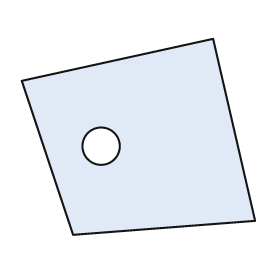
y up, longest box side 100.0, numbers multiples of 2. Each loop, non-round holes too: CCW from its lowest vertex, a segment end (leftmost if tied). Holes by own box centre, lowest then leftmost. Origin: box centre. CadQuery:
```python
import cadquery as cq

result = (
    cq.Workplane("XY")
    .moveTo(-28.0, -42.0)
    .lineTo(50.0, -36.0)
    .lineTo(32.0, 42.0)
    .lineTo(-50.0, 24.0)
    .close()
    .moveTo(-16.0, -4.0)
    .circle(8.0)
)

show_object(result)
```